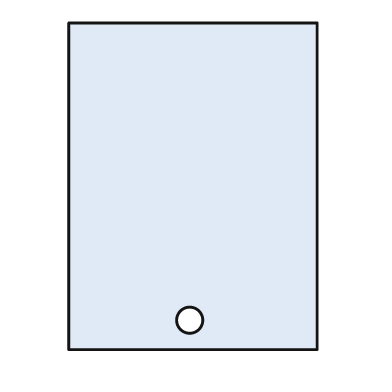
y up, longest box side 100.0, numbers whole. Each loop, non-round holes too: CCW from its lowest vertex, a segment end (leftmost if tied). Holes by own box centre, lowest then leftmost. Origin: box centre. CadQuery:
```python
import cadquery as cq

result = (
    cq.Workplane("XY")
    .moveTo(-38.0, -50.0)
    .lineTo(38.0, -50.0)
    .lineTo(38.0, 50.0)
    .lineTo(-38.0, 50.0)
    .close()
    .moveTo(-1.0, -41.0)
    .circle(4.0)
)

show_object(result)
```